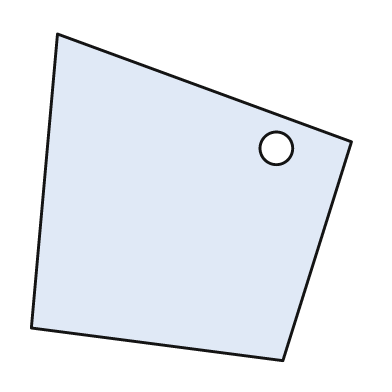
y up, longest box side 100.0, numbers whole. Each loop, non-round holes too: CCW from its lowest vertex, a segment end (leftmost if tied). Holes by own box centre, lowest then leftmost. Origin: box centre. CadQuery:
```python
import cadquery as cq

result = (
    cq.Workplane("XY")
    .moveTo(28.0, -50.0)
    .lineTo(49.0, 17.0)
    .lineTo(-41.0, 50.0)
    .lineTo(-49.0, -40.0)
    .close()
    .moveTo(26.0, 15.0)
    .circle(5.0)
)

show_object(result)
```